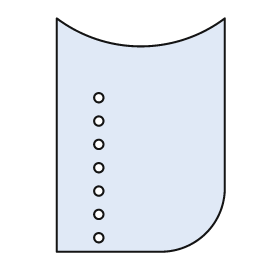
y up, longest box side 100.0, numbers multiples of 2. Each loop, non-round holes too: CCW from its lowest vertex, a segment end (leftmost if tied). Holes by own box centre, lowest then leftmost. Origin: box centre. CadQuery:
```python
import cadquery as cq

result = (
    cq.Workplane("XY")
    .moveTo(-36.0, -50.0)
    .lineTo(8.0, -50.0)
    .threePointArc((28.0, -42.0), (36.0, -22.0))
    .lineTo(36.0, 50.0)
    .threePointArc((0.0, 38.0), (-36.0, 50.0))
    .close()
    .moveTo(-18.0, -44.0)
    .circle(2.0)
    .moveTo(-18.0, -34.0)
    .circle(2.0)
    .moveTo(-18.0, -24.0)
    .circle(2.0)
    .moveTo(-18.0, -14.0)
    .circle(2.0)
    .moveTo(-18.0, -4.0)
    .circle(2.0)
    .moveTo(-18.0, 6.0)
    .circle(2.0)
    .moveTo(-18.0, 16.0)
    .circle(2.0)
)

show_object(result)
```